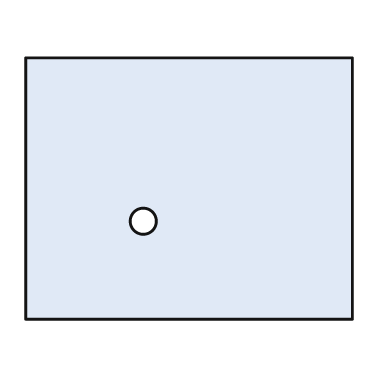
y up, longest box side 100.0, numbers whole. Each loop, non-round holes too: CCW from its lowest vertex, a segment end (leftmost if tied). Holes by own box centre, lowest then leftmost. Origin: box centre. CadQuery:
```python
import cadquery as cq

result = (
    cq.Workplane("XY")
    .moveTo(-50.0, -40.0)
    .lineTo(50.0, -40.0)
    .lineTo(50.0, 40.0)
    .lineTo(-50.0, 40.0)
    .close()
    .moveTo(-14.0, -10.0)
    .circle(4.0)
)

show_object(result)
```